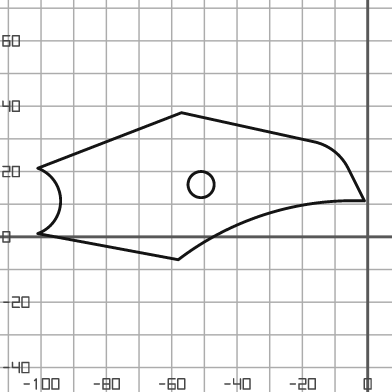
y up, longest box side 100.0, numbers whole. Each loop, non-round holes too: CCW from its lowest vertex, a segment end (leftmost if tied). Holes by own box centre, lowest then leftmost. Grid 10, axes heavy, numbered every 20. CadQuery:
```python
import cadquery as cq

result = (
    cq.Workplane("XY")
    .moveTo(-58.0, -7.0)
    .threePointArc((-31.0, 7.0), (-1.0, 11.0))
    .lineTo(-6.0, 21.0)
    .threePointArc((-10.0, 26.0), (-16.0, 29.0))
    .lineTo(-57.0, 38.0)
    .lineTo(-101.0, 21.0)
    .threePointArc((-94.0, 11.0), (-101.0, 1.0))
    .close()
    .moveTo(-51.0, 16.0)
    .circle(4.0)
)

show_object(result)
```